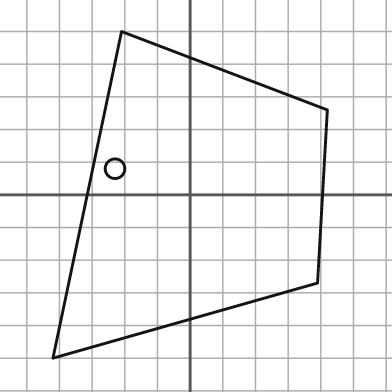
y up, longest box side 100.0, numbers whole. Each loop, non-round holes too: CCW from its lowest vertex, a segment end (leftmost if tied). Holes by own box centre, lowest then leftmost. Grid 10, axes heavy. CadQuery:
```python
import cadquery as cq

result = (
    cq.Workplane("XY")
    .moveTo(-42.0, -50.0)
    .lineTo(39.0, -27.0)
    .lineTo(42.0, 26.0)
    .lineTo(-21.0, 50.0)
    .close()
    .moveTo(-23.0, 8.0)
    .circle(3.0)
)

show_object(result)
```